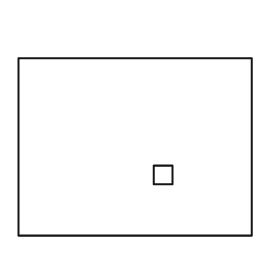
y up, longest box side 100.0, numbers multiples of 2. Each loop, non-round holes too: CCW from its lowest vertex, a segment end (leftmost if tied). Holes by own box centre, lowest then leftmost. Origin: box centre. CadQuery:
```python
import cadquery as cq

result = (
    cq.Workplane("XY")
    .moveTo(-50.0, -38.0)
    .lineTo(50.0, -38.0)
    .lineTo(50.0, 38.0)
    .lineTo(-50.0, 38.0)
    .close()
    .moveTo(8.0, -16.0)
    .lineTo(16.0, -16.0)
    .lineTo(16.0, -8.0)
    .lineTo(8.0, -8.0)
    .close()
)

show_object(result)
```